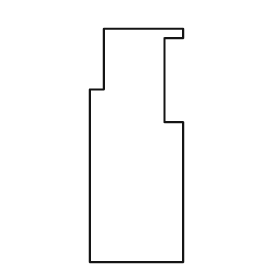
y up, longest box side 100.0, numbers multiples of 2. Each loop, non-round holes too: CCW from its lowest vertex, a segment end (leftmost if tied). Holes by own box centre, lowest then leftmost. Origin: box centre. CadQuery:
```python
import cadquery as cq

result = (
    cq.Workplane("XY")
    .moveTo(-20.0, -50.0)
    .lineTo(20.0, -50.0)
    .lineTo(20.0, 10.0)
    .lineTo(12.0, 10.0)
    .lineTo(12.0, 46.0)
    .lineTo(20.0, 46.0)
    .lineTo(20.0, 50.0)
    .lineTo(-14.0, 50.0)
    .lineTo(-14.0, 24.0)
    .lineTo(-20.0, 24.0)
    .close()
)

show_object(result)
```